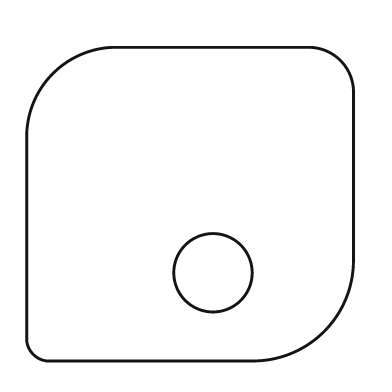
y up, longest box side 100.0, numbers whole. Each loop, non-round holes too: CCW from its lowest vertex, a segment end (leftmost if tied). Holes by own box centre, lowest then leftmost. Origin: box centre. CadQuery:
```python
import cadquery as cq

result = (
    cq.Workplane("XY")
    .moveTo(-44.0, -48.0)
    .lineTo(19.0, -48.0)
    .threePointArc((41.0, -39.0), (50.0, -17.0))
    .lineTo(50.0, 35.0)
    .threePointArc((46.0, 44.0), (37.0, 48.0))
    .lineTo(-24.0, 48.0)
    .threePointArc((-42.0, 40.0), (-50.0, 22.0))
    .lineTo(-50.0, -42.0)
    .threePointArc((-48.0, -46.0), (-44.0, -48.0))
    .close()
    .moveTo(7.0, -21.0)
    .circle(12.0)
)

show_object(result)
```